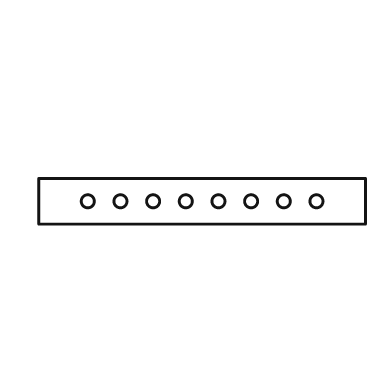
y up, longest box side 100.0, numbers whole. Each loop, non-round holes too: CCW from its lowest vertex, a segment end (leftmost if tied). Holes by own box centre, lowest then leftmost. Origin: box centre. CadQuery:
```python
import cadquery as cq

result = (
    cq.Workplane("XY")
    .moveTo(-50.0, -7.0)
    .lineTo(50.0, -7.0)
    .lineTo(50.0, 7.0)
    .lineTo(-50.0, 7.0)
    .close()
    .moveTo(-35.0, 0.0)
    .circle(2.0)
    .moveTo(-25.0, 0.0)
    .circle(2.0)
    .moveTo(-15.0, 0.0)
    .circle(2.0)
    .moveTo(-5.0, 0.0)
    .circle(2.0)
    .moveTo(5.0, 0.0)
    .circle(2.0)
    .moveTo(15.0, 0.0)
    .circle(2.0)
    .moveTo(25.0, 0.0)
    .circle(2.0)
    .moveTo(35.0, 0.0)
    .circle(2.0)
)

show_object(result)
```